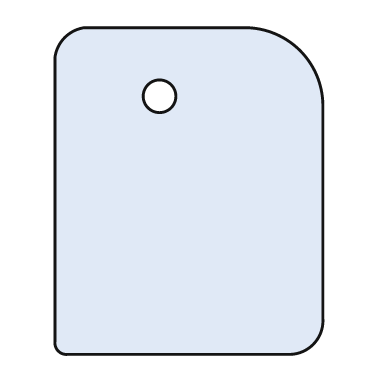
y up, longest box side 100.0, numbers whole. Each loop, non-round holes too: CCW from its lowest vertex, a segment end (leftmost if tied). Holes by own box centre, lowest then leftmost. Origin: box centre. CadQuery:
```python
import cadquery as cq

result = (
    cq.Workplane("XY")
    .moveTo(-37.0, -50.0)
    .lineTo(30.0, -50.0)
    .threePointArc((38.0, -47.0), (41.0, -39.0))
    .lineTo(41.0, 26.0)
    .threePointArc((34.0, 43.0), (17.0, 50.0))
    .lineTo(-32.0, 50.0)
    .threePointArc((-38.0, 47.0), (-41.0, 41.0))
    .lineTo(-41.0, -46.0)
    .threePointArc((-40.0, -49.0), (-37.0, -50.0))
    .close()
    .moveTo(-9.0, 29.0)
    .circle(5.0)
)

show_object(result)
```